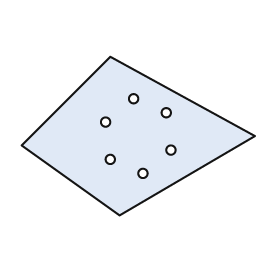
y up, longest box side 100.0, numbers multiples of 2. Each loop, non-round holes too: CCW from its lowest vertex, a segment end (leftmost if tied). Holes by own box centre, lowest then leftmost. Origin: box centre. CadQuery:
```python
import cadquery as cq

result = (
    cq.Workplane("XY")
    .moveTo(-8.0, -34.0)
    .lineTo(50.0, 0.0)
    .lineTo(-12.0, 34.0)
    .lineTo(-50.0, -4.0)
    .close()
    .moveTo(2.0, -16.0)
    .circle(2.0)
    .moveTo(-12.0, -10.0)
    .circle(2.0)
    .moveTo(14.0, -6.0)
    .circle(2.0)
    .moveTo(-14.0, 6.0)
    .circle(2.0)
    .moveTo(12.0, 10.0)
    .circle(2.0)
    .moveTo(-2.0, 16.0)
    .circle(2.0)
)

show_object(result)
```